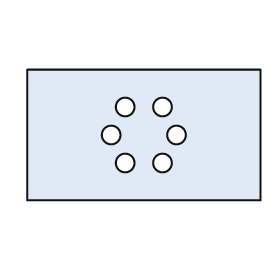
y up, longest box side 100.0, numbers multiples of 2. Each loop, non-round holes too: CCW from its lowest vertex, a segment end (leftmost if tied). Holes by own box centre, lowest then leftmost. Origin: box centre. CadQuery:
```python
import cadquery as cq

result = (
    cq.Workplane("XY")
    .moveTo(-50.0, -28.0)
    .lineTo(50.0, -28.0)
    .lineTo(50.0, 28.0)
    .lineTo(-50.0, 28.0)
    .close()
    .moveTo(-8.0, -12.0)
    .circle(4.0)
    .moveTo(8.0, -12.0)
    .circle(4.0)
    .moveTo(-14.0, 0.0)
    .circle(4.0)
    .moveTo(14.0, 0.0)
    .circle(4.0)
    .moveTo(-8.0, 12.0)
    .circle(4.0)
    .moveTo(8.0, 12.0)
    .circle(4.0)
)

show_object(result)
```